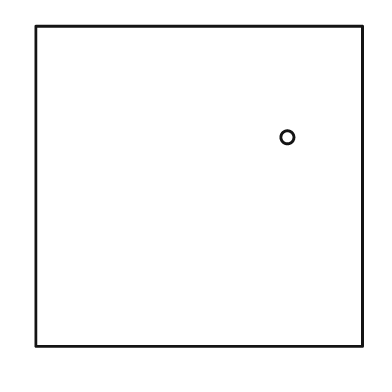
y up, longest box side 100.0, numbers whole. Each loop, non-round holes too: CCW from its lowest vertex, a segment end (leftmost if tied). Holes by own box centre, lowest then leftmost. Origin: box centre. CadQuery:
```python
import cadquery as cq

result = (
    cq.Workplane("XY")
    .moveTo(-50.0, -49.0)
    .lineTo(50.0, -49.0)
    .lineTo(50.0, 49.0)
    .lineTo(-50.0, 49.0)
    .close()
    .moveTo(27.0, 15.0)
    .circle(2.0)
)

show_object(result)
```